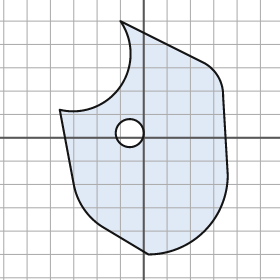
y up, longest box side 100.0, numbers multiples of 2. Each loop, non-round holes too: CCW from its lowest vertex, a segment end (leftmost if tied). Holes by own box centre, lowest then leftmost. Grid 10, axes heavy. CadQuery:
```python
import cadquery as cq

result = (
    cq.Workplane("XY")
    .moveTo(2.0, -50.0)
    .threePointArc((26.0, -40.0), (36.0, -16.0))
    .lineTo(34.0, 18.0)
    .threePointArc((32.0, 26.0), (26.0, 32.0))
    .lineTo(-10.0, 50.0)
    .threePointArc((-10.0, 22.0), (-36.0, 12.0))
    .lineTo(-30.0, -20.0)
    .threePointArc((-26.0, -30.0), (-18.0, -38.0))
    .close()
    .moveTo(-6.0, 2.0)
    .circle(6.0)
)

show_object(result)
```